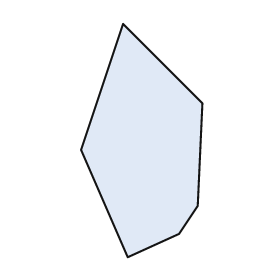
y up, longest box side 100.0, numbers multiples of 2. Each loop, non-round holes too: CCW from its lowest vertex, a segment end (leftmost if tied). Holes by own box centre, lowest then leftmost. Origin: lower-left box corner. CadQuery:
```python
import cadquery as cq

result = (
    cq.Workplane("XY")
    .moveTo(20.0, 0.0)
    .lineTo(42.0, 10.0)
    .lineTo(50.0, 22.0)
    .lineTo(52.0, 66.0)
    .lineTo(18.0, 100.0)
    .lineTo(0.0, 46.0)
    .close()
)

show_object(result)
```